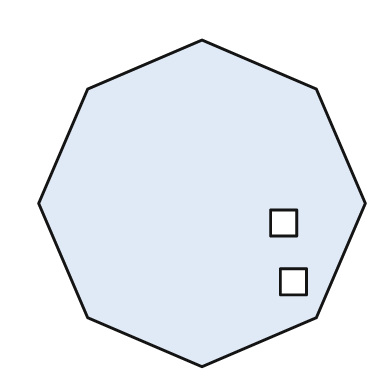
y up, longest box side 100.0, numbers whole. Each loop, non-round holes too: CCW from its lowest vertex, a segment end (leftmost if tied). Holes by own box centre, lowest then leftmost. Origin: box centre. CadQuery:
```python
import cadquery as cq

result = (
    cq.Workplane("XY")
    .moveTo(0.0, -50.0)
    .lineTo(35.0, -35.0)
    .lineTo(50.0, 0.0)
    .lineTo(35.0, 35.0)
    .lineTo(0.0, 50.0)
    .lineTo(-35.0, 35.0)
    .lineTo(-50.0, 0.0)
    .lineTo(-35.0, -35.0)
    .close()
    .moveTo(24.0, -28.0)
    .lineTo(32.0, -28.0)
    .lineTo(32.0, -20.0)
    .lineTo(24.0, -20.0)
    .close()
    .moveTo(21.0, -10.0)
    .lineTo(29.0, -10.0)
    .lineTo(29.0, -2.0)
    .lineTo(21.0, -2.0)
    .close()
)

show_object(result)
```